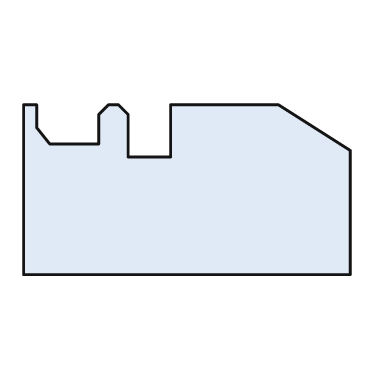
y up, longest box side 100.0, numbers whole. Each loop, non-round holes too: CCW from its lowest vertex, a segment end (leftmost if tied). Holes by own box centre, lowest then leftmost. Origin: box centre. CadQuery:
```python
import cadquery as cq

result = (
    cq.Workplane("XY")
    .moveTo(-50.0, -26.0)
    .lineTo(50.0, -26.0)
    .lineTo(50.0, 12.0)
    .lineTo(28.0, 26.0)
    .lineTo(-5.0, 26.0)
    .lineTo(-5.0, 10.0)
    .lineTo(-18.0, 10.0)
    .lineTo(-18.0, 23.0)
    .lineTo(-21.0, 26.0)
    .lineTo(-24.0, 26.0)
    .lineTo(-27.0, 23.0)
    .lineTo(-27.0, 14.0)
    .lineTo(-42.0, 14.0)
    .lineTo(-46.0, 19.0)
    .lineTo(-46.0, 26.0)
    .lineTo(-50.0, 26.0)
    .close()
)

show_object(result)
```